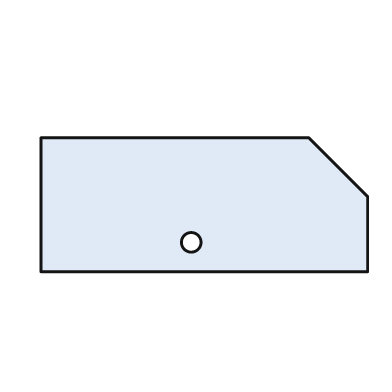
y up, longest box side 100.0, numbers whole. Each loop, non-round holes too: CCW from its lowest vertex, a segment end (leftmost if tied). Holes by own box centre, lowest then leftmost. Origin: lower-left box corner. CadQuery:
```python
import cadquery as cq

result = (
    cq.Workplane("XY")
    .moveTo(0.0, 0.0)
    .lineTo(100.0, 0.0)
    .lineTo(100.0, 23.0)
    .lineTo(82.0, 41.0)
    .lineTo(0.0, 41.0)
    .close()
    .moveTo(46.0, 9.0)
    .circle(3.0)
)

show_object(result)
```